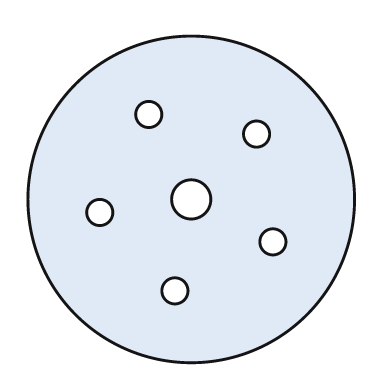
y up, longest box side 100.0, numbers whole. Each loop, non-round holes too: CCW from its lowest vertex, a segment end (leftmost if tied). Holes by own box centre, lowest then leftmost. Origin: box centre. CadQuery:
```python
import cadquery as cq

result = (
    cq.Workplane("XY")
    .moveTo(0.0, 0.0)
    .circle(50.0)
    .moveTo(-5.0, -28.0)
    .circle(4.0)
    .moveTo(25.0, -13.0)
    .circle(4.0)
    .moveTo(-28.0, -4.0)
    .circle(4.0)
    .moveTo(0.0, 0.0)
    .circle(6.0)
    .moveTo(20.0, 20.0)
    .circle(4.0)
    .moveTo(-13.0, 26.0)
    .circle(4.0)
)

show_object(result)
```